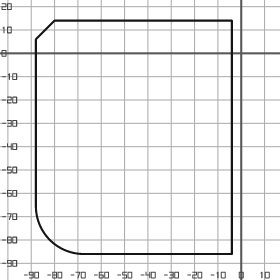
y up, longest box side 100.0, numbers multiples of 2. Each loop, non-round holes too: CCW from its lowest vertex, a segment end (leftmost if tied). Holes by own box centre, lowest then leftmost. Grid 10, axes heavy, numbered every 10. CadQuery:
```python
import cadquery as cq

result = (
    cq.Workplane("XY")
    .moveTo(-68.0, -86.0)
    .lineTo(-4.0, -86.0)
    .lineTo(-4.0, 14.0)
    .lineTo(-80.0, 14.0)
    .lineTo(-88.0, 6.0)
    .lineTo(-88.0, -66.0)
    .threePointArc((-82.0, -80.0), (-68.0, -86.0))
    .close()
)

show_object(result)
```